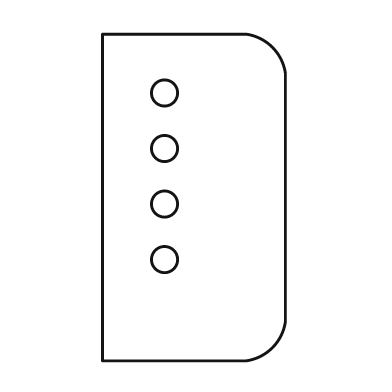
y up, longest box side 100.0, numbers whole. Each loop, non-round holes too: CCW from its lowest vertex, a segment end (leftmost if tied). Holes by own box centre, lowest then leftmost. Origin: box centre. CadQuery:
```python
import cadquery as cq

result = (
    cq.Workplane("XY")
    .moveTo(-28.0, -50.0)
    .lineTo(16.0, -50.0)
    .threePointArc((24.0, -46.0), (28.0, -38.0))
    .lineTo(28.0, 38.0)
    .threePointArc((24.0, 46.0), (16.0, 50.0))
    .lineTo(-28.0, 50.0)
    .close()
    .moveTo(-9.0, -19.0)
    .circle(4.0)
    .moveTo(-9.0, -2.0)
    .circle(4.0)
    .moveTo(-9.0, 15.0)
    .circle(4.0)
    .moveTo(-9.0, 32.0)
    .circle(4.0)
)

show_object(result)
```